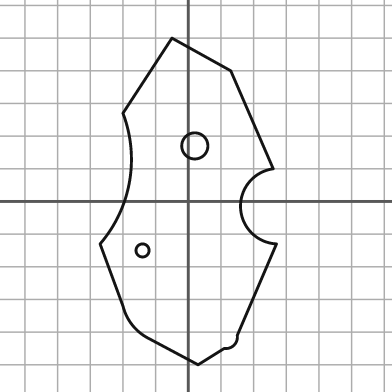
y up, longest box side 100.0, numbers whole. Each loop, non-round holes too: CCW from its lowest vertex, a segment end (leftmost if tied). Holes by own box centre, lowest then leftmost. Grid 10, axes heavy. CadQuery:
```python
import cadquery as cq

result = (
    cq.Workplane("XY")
    .moveTo(3.0, -50.0)
    .lineTo(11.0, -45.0)
    .threePointArc((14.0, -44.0), (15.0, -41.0))
    .lineTo(27.0, -13.0)
    .threePointArc((16.0, -2.0), (26.0, 10.0))
    .lineTo(13.0, 40.0)
    .lineTo(-5.0, 50.0)
    .lineTo(-20.0, 27.0)
    .threePointArc((-18.0, 6.0), (-27.0, -13.0))
    .lineTo(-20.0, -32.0)
    .threePointArc((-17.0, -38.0), (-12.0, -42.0))
    .close()
    .moveTo(-14.0, -15.0)
    .circle(2.0)
    .moveTo(2.0, 17.0)
    .circle(4.0)
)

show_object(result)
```